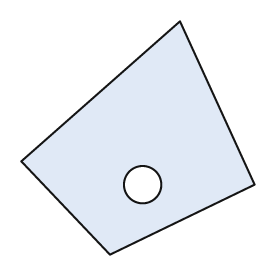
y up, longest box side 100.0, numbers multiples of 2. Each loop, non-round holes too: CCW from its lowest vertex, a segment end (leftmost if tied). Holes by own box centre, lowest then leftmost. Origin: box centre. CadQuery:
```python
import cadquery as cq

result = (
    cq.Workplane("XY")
    .moveTo(-12.0, -50.0)
    .lineTo(50.0, -20.0)
    .lineTo(18.0, 50.0)
    .lineTo(-50.0, -10.0)
    .close()
    .moveTo(2.0, -20.0)
    .circle(8.0)
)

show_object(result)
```